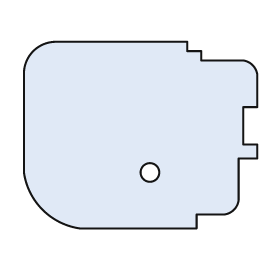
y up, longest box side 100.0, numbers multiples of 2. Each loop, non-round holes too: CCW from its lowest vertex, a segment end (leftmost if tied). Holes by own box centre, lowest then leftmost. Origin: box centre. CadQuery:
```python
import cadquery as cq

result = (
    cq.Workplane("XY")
    .moveTo(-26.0, -40.0)
    .lineTo(24.0, -40.0)
    .lineTo(24.0, -34.0)
    .lineTo(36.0, -34.0)
    .threePointArc((40.0, -32.0), (42.0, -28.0))
    .lineTo(42.0, -10.0)
    .lineTo(50.0, -10.0)
    .lineTo(50.0, -4.0)
    .lineTo(44.0, -4.0)
    .lineTo(44.0, 12.0)
    .lineTo(50.0, 12.0)
    .lineTo(50.0, 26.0)
    .threePointArc((48.0, 30.0), (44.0, 32.0))
    .lineTo(26.0, 32.0)
    .lineTo(26.0, 36.0)
    .lineTo(20.0, 36.0)
    .lineTo(20.0, 40.0)
    .lineTo(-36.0, 40.0)
    .threePointArc((-46.0, 36.0), (-50.0, 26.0))
    .lineTo(-50.0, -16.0)
    .threePointArc((-42.0, -32.0), (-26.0, -40.0))
    .close()
    .moveTo(4.0, -16.0)
    .circle(4.0)
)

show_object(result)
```